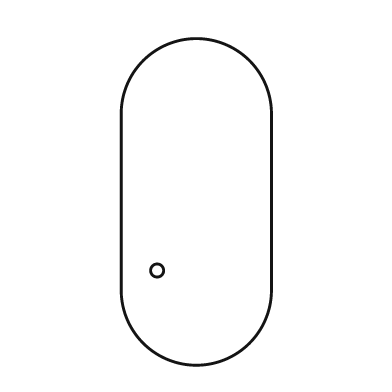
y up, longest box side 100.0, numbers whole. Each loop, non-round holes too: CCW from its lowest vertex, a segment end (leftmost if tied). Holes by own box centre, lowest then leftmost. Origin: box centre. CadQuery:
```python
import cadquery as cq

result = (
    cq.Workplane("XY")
    .moveTo(-23.0, -27.0)
    .threePointArc((0.0, -50.0), (23.0, -27.0))
    .lineTo(23.0, 27.0)
    .threePointArc((0.0, 50.0), (-23.0, 27.0))
    .close()
    .moveTo(-12.0, -21.0)
    .circle(2.0)
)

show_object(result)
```